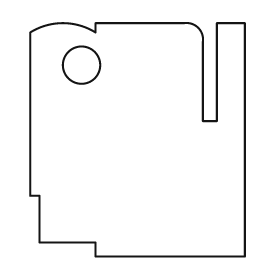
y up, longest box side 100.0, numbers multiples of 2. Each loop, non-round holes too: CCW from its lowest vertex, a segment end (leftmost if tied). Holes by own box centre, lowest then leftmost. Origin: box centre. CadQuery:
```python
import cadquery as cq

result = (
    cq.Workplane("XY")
    .moveTo(-18.0, -50.0)
    .lineTo(46.0, -50.0)
    .lineTo(46.0, 50.0)
    .lineTo(34.0, 50.0)
    .lineTo(34.0, 8.0)
    .lineTo(28.0, 8.0)
    .lineTo(28.0, 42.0)
    .threePointArc((26.0, 48.0), (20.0, 50.0))
    .lineTo(-18.0, 50.0)
    .lineTo(-18.0, 46.0)
    .threePointArc((-32.0, 50.0), (-46.0, 46.0))
    .lineTo(-46.0, -24.0)
    .lineTo(-42.0, -24.0)
    .lineTo(-42.0, -44.0)
    .lineTo(-18.0, -44.0)
    .close()
    .moveTo(-24.0, 32.0)
    .circle(8.0)
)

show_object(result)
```